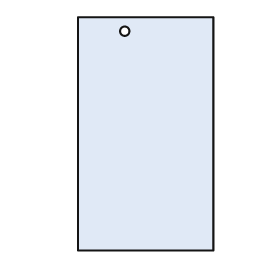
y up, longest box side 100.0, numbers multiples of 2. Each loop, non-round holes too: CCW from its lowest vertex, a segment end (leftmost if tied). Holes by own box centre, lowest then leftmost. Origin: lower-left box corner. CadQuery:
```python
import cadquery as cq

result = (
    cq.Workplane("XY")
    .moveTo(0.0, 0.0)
    .lineTo(58.0, 0.0)
    .lineTo(58.0, 100.0)
    .lineTo(0.0, 100.0)
    .close()
    .moveTo(20.0, 94.0)
    .circle(2.0)
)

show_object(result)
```